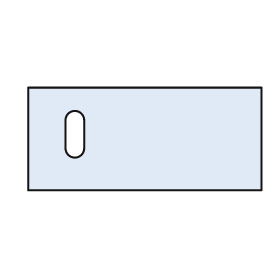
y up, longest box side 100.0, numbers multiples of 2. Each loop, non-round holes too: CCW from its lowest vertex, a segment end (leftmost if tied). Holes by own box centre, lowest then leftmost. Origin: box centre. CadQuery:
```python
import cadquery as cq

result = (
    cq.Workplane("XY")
    .moveTo(-50.0, -22.0)
    .lineTo(50.0, -22.0)
    .lineTo(50.0, 22.0)
    .lineTo(-50.0, 22.0)
    .close()
    .moveTo(-34.0, -4.0)
    .threePointArc((-30.0, -8.0), (-26.0, -4.0))
    .lineTo(-26.0, 8.0)
    .threePointArc((-30.0, 12.0), (-34.0, 8.0))
    .close()
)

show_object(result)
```